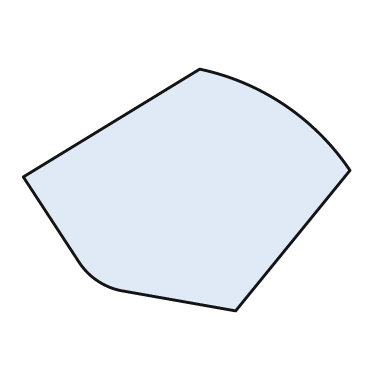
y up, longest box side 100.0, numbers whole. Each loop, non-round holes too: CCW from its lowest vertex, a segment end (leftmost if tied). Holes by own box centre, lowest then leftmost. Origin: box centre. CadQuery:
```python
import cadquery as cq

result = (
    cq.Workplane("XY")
    .moveTo(15.0, -37.0)
    .lineTo(50.0, 6.0)
    .threePointArc((30.0, 26.0), (4.0, 37.0))
    .lineTo(-50.0, 4.0)
    .lineTo(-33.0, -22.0)
    .threePointArc((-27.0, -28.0), (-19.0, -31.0))
    .close()
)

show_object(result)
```